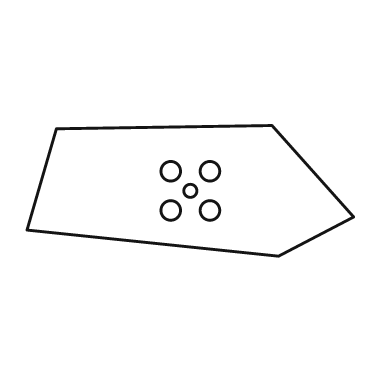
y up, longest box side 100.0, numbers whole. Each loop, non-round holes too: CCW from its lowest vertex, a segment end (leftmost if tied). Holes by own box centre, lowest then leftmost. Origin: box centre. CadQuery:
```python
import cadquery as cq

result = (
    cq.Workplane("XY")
    .moveTo(27.0, -20.0)
    .lineTo(50.0, -8.0)
    .lineTo(25.0, 20.0)
    .lineTo(-41.0, 19.0)
    .lineTo(-50.0, -12.0)
    .close()
    .moveTo(-6.0, -6.0)
    .circle(3.0)
    .moveTo(6.0, -6.0)
    .circle(3.0)
    .moveTo(0.0, 0.0)
    .circle(2.0)
    .moveTo(-6.0, 6.0)
    .circle(3.0)
    .moveTo(6.0, 6.0)
    .circle(3.0)
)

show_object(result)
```